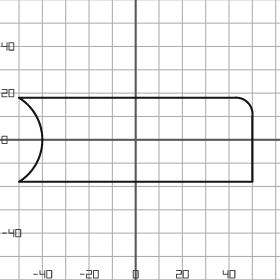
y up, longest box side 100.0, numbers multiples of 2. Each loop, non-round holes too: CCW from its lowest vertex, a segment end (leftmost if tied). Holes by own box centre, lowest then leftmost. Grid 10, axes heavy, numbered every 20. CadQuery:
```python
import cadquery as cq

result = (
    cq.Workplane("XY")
    .moveTo(-50.0, -18.0)
    .lineTo(50.0, -18.0)
    .lineTo(50.0, 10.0)
    .threePointArc((48.0, 16.0), (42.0, 18.0))
    .lineTo(-50.0, 18.0)
    .threePointArc((-40.0, 0.0), (-50.0, -18.0))
    .close()
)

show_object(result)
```